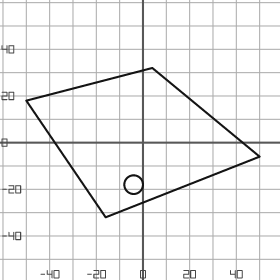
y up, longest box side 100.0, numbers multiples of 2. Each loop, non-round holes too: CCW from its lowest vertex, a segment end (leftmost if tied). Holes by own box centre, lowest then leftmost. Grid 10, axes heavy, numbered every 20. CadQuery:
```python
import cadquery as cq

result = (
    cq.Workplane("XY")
    .moveTo(-16.0, -32.0)
    .lineTo(50.0, -6.0)
    .lineTo(4.0, 32.0)
    .lineTo(-50.0, 18.0)
    .close()
    .moveTo(-4.0, -18.0)
    .circle(4.0)
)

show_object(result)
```